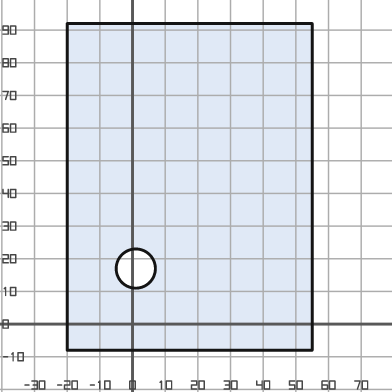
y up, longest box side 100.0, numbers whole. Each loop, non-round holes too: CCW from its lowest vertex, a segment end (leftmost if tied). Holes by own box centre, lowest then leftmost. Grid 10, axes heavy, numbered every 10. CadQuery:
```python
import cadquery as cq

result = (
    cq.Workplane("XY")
    .moveTo(-20.0, -8.0)
    .lineTo(55.0, -8.0)
    .lineTo(55.0, 92.0)
    .lineTo(-20.0, 92.0)
    .close()
    .moveTo(1.0, 17.0)
    .circle(6.0)
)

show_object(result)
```